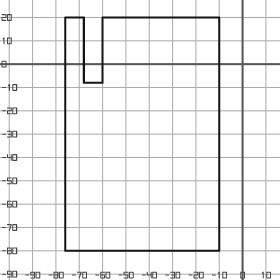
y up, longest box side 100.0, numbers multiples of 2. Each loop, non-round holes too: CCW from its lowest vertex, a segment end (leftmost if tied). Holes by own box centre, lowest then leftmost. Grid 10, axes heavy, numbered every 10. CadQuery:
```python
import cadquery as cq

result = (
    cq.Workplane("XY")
    .moveTo(-76.0, -80.0)
    .lineTo(-10.0, -80.0)
    .lineTo(-10.0, 20.0)
    .lineTo(-60.0, 20.0)
    .lineTo(-60.0, -8.0)
    .lineTo(-68.0, -8.0)
    .lineTo(-68.0, 20.0)
    .lineTo(-76.0, 20.0)
    .close()
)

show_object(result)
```